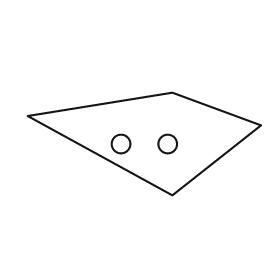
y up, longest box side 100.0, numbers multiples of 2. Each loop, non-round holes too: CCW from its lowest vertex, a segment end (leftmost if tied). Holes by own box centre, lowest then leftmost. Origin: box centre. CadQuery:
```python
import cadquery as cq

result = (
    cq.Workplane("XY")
    .moveTo(12.0, -22.0)
    .lineTo(50.0, 8.0)
    .lineTo(12.0, 22.0)
    .lineTo(-50.0, 12.0)
    .close()
    .moveTo(-10.0, 0.0)
    .circle(4.0)
    .moveTo(10.0, 0.0)
    .circle(4.0)
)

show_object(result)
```